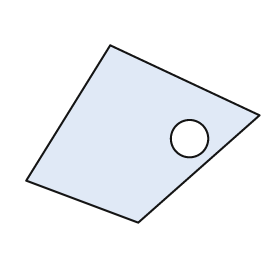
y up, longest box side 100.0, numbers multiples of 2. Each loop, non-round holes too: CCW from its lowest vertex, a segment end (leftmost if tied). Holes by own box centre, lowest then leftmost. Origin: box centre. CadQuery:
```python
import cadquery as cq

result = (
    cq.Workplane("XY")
    .moveTo(-2.0, -38.0)
    .lineTo(50.0, 8.0)
    .lineTo(-14.0, 38.0)
    .lineTo(-50.0, -20.0)
    .close()
    .moveTo(20.0, -2.0)
    .circle(8.0)
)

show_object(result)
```